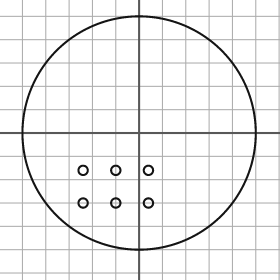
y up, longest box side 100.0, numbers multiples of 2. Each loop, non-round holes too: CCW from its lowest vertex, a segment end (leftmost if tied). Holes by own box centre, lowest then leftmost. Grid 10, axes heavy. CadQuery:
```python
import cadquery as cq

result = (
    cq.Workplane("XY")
    .moveTo(0.0, 0.0)
    .circle(50.0)
    .moveTo(-24.0, -30.0)
    .circle(2.0)
    .moveTo(-10.0, -30.0)
    .circle(2.0)
    .moveTo(4.0, -30.0)
    .circle(2.0)
    .moveTo(-24.0, -16.0)
    .circle(2.0)
    .moveTo(-10.0, -16.0)
    .circle(2.0)
    .moveTo(4.0, -16.0)
    .circle(2.0)
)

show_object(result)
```